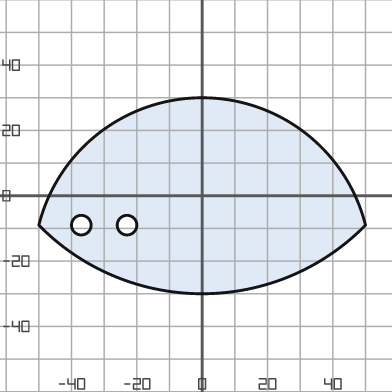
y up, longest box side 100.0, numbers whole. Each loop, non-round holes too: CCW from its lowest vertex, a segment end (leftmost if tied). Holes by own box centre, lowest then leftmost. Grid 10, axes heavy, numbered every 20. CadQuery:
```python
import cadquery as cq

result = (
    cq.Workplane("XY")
    .moveTo(-50.0, -9.0)
    .threePointArc((0.0, -30.0), (50.0, -9.0))
    .threePointArc((0.0, 30.0), (-50.0, -9.0))
    .close()
    .moveTo(-37.0, -9.0)
    .circle(3.0)
    .moveTo(-23.0, -9.0)
    .circle(3.0)
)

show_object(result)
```